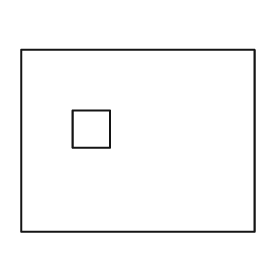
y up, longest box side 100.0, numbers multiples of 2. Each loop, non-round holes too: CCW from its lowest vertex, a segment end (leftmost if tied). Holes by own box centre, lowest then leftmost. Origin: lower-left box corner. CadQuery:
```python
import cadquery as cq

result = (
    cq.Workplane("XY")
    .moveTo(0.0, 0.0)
    .lineTo(100.0, 0.0)
    .lineTo(100.0, 78.0)
    .lineTo(0.0, 78.0)
    .close()
    .moveTo(22.0, 36.0)
    .lineTo(38.0, 36.0)
    .lineTo(38.0, 52.0)
    .lineTo(22.0, 52.0)
    .close()
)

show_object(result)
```